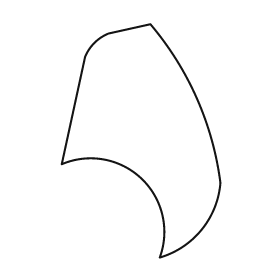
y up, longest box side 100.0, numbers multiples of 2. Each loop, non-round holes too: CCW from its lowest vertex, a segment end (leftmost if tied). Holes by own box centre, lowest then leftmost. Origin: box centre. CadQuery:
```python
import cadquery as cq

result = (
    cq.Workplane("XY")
    .moveTo(8.0, -50.0)
    .threePointArc((26.0, -38.0), (34.0, -18.0))
    .threePointArc((24.0, 18.0), (4.0, 50.0))
    .lineTo(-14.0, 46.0)
    .threePointArc((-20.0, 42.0), (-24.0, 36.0))
    .lineTo(-34.0, -10.0)
    .threePointArc((0.0, -16.0), (8.0, -50.0))
    .close()
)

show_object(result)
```